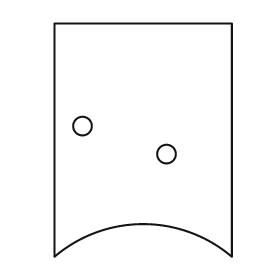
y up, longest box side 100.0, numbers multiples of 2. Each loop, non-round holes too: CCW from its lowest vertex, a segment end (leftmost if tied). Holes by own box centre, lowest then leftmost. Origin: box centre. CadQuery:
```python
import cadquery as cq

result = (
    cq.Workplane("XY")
    .moveTo(-38.0, -50.0)
    .threePointArc((0.0, -36.0), (38.0, -50.0))
    .lineTo(38.0, 50.0)
    .lineTo(-38.0, 50.0)
    .close()
    .moveTo(10.0, -6.0)
    .circle(4.0)
    .moveTo(-26.0, 6.0)
    .circle(4.0)
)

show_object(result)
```